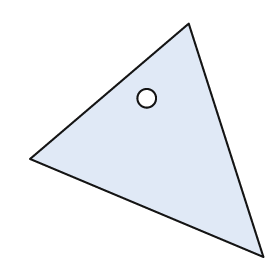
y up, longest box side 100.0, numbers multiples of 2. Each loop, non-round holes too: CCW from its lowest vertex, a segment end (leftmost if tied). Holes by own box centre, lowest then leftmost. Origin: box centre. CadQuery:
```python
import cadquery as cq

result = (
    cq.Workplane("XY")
    .moveTo(50.0, -50.0)
    .lineTo(18.0, 50.0)
    .lineTo(-50.0, -8.0)
    .close()
    .moveTo(0.0, 18.0)
    .circle(4.0)
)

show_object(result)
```